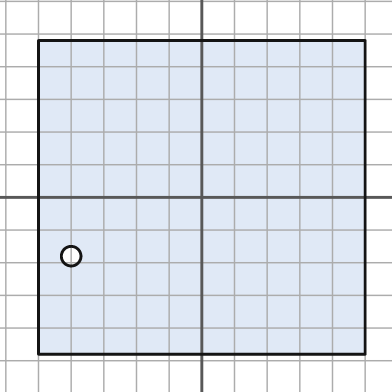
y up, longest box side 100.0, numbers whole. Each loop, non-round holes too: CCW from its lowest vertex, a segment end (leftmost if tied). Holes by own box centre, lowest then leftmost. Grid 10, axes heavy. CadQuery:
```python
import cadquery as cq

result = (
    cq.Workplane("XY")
    .moveTo(-50.0, -48.0)
    .lineTo(50.0, -48.0)
    .lineTo(50.0, 48.0)
    .lineTo(-50.0, 48.0)
    .close()
    .moveTo(-40.0, -18.0)
    .circle(3.0)
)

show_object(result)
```